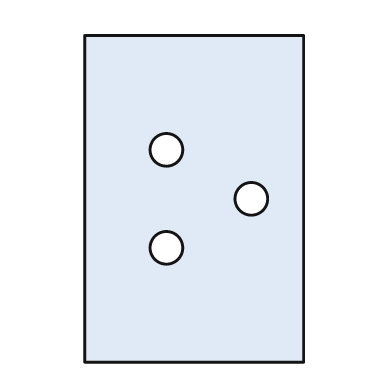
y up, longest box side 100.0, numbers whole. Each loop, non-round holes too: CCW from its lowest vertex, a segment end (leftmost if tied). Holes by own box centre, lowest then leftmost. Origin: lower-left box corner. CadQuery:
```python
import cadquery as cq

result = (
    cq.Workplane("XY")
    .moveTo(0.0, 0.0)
    .lineTo(67.0, 0.0)
    .lineTo(67.0, 100.0)
    .lineTo(0.0, 100.0)
    .close()
    .moveTo(25.0, 35.0)
    .circle(5.0)
    .moveTo(51.0, 50.0)
    .circle(5.0)
    .moveTo(25.0, 65.0)
    .circle(5.0)
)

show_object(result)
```